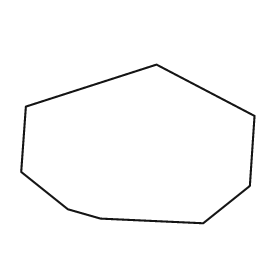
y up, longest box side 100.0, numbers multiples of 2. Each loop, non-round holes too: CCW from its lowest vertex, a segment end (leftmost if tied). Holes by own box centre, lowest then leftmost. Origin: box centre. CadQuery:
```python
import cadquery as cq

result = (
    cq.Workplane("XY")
    .moveTo(28.0, -34.0)
    .lineTo(48.0, -18.0)
    .lineTo(50.0, 12.0)
    .lineTo(8.0, 34.0)
    .lineTo(-48.0, 16.0)
    .lineTo(-50.0, -12.0)
    .lineTo(-30.0, -28.0)
    .lineTo(-16.0, -32.0)
    .close()
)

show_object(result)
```